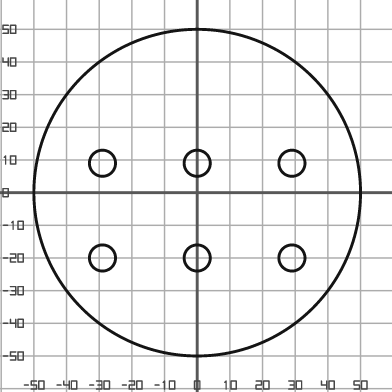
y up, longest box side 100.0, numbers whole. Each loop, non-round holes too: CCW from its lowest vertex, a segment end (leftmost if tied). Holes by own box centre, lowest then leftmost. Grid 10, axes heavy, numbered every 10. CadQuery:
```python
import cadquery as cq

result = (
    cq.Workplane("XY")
    .moveTo(0.0, 0.0)
    .circle(50.0)
    .moveTo(-29.0, -20.0)
    .circle(4.0)
    .moveTo(0.0, -20.0)
    .circle(4.0)
    .moveTo(29.0, -20.0)
    .circle(4.0)
    .moveTo(-29.0, 9.0)
    .circle(4.0)
    .moveTo(0.0, 9.0)
    .circle(4.0)
    .moveTo(29.0, 9.0)
    .circle(4.0)
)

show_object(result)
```